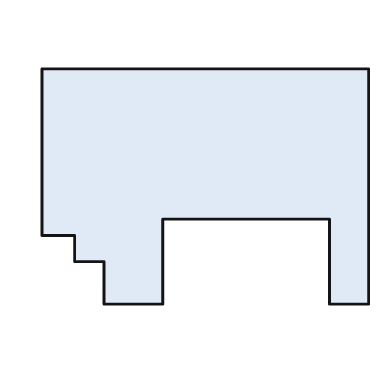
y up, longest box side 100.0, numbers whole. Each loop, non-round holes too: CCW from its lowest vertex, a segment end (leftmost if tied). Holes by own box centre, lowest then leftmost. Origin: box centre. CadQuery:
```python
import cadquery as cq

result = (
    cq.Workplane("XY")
    .moveTo(-31.0, -36.0)
    .lineTo(-13.0, -36.0)
    .lineTo(-13.0, -10.0)
    .lineTo(38.0, -10.0)
    .lineTo(38.0, -36.0)
    .lineTo(50.0, -36.0)
    .lineTo(50.0, 36.0)
    .lineTo(-50.0, 36.0)
    .lineTo(-50.0, -15.0)
    .lineTo(-40.0, -15.0)
    .lineTo(-40.0, -23.0)
    .lineTo(-31.0, -23.0)
    .close()
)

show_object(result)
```